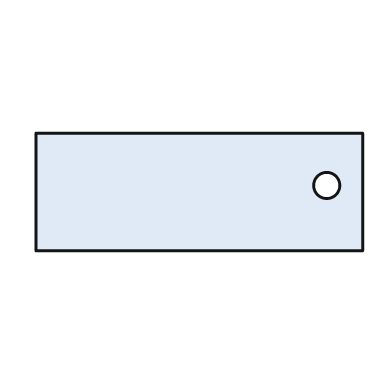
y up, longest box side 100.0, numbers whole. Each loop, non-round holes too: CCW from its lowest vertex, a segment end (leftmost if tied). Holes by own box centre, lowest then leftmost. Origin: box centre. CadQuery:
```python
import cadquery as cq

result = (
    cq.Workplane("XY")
    .moveTo(-50.0, -18.0)
    .lineTo(50.0, -18.0)
    .lineTo(50.0, 18.0)
    .lineTo(-50.0, 18.0)
    .close()
    .moveTo(39.0, 2.0)
    .circle(4.0)
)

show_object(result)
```